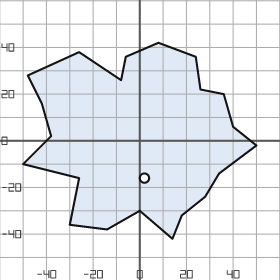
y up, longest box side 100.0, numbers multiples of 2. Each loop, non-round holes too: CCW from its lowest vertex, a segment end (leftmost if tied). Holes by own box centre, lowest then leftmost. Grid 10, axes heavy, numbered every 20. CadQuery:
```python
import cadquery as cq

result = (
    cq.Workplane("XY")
    .moveTo(14.0, -42.0)
    .lineTo(18.0, -32.0)
    .lineTo(28.0, -24.0)
    .lineTo(34.0, -14.0)
    .lineTo(50.0, -2.0)
    .lineTo(40.0, 6.0)
    .lineTo(36.0, 20.0)
    .lineTo(26.0, 22.0)
    .lineTo(24.0, 36.0)
    .lineTo(8.0, 42.0)
    .lineTo(-6.0, 36.0)
    .lineTo(-8.0, 26.0)
    .lineTo(-26.0, 38.0)
    .lineTo(-48.0, 28.0)
    .lineTo(-42.0, 16.0)
    .lineTo(-38.0, 2.0)
    .lineTo(-50.0, -10.0)
    .lineTo(-26.0, -16.0)
    .lineTo(-30.0, -36.0)
    .lineTo(-14.0, -38.0)
    .lineTo(0.0, -30.0)
    .close()
    .moveTo(2.0, -16.0)
    .circle(2.0)
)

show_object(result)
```